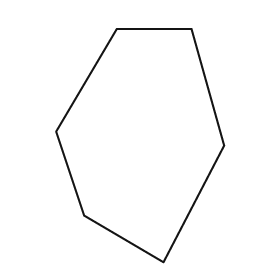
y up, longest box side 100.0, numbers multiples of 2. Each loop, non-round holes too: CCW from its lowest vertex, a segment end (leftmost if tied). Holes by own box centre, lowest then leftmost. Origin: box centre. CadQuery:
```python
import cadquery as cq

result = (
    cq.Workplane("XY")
    .moveTo(10.0, -50.0)
    .lineTo(36.0, 0.0)
    .lineTo(22.0, 50.0)
    .lineTo(-10.0, 50.0)
    .lineTo(-36.0, 6.0)
    .lineTo(-24.0, -30.0)
    .close()
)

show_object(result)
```